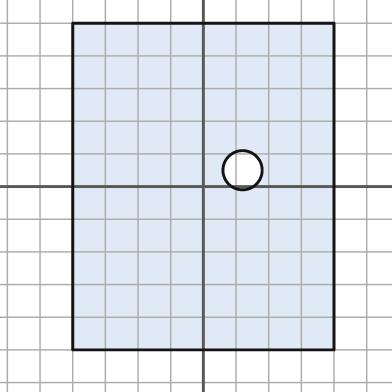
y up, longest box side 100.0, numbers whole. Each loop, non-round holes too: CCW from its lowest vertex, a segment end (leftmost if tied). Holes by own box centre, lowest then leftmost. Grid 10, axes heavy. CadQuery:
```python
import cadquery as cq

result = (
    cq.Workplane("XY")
    .moveTo(-40.0, -50.0)
    .lineTo(40.0, -50.0)
    .lineTo(40.0, 50.0)
    .lineTo(-40.0, 50.0)
    .close()
    .moveTo(12.0, 5.0)
    .circle(6.0)
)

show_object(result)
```